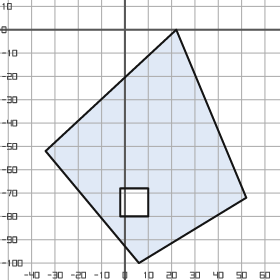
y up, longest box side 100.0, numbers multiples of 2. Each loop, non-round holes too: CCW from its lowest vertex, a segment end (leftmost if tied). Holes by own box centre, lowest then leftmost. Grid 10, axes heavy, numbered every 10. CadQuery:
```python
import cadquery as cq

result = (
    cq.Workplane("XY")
    .moveTo(6.0, -100.0)
    .lineTo(52.0, -72.0)
    .lineTo(22.0, 0.0)
    .lineTo(-34.0, -52.0)
    .close()
    .moveTo(-2.0, -80.0)
    .lineTo(10.0, -80.0)
    .lineTo(10.0, -68.0)
    .lineTo(-2.0, -68.0)
    .close()
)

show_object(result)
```